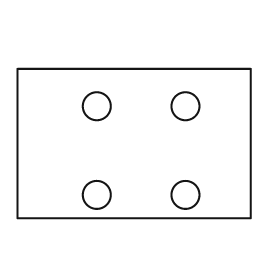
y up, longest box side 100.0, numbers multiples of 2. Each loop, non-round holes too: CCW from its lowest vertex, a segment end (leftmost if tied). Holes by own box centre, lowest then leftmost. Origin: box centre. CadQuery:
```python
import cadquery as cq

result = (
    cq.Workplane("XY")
    .moveTo(-50.0, -32.0)
    .lineTo(50.0, -32.0)
    .lineTo(50.0, 32.0)
    .lineTo(-50.0, 32.0)
    .close()
    .moveTo(-16.0, -22.0)
    .circle(6.0)
    .moveTo(22.0, -22.0)
    .circle(6.0)
    .moveTo(-16.0, 16.0)
    .circle(6.0)
    .moveTo(22.0, 16.0)
    .circle(6.0)
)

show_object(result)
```